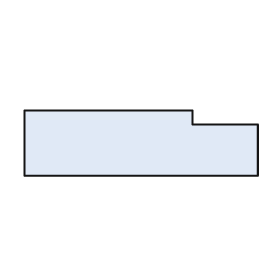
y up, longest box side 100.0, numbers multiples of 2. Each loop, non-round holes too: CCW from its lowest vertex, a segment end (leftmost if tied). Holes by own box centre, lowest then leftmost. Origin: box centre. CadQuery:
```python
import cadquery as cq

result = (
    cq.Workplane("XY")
    .moveTo(-50.0, -14.0)
    .lineTo(50.0, -14.0)
    .lineTo(50.0, 8.0)
    .lineTo(22.0, 8.0)
    .lineTo(22.0, 14.0)
    .lineTo(-50.0, 14.0)
    .close()
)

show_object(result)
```